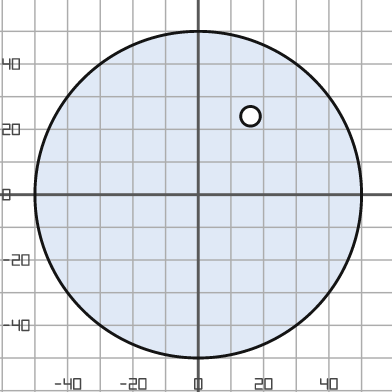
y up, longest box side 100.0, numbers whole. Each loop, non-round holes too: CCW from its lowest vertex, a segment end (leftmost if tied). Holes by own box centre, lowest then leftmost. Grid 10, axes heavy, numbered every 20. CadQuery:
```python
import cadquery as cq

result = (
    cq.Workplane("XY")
    .moveTo(0.0, 0.0)
    .circle(50.0)
    .moveTo(16.0, 24.0)
    .circle(3.0)
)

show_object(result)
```